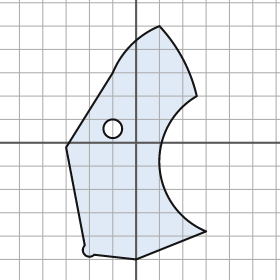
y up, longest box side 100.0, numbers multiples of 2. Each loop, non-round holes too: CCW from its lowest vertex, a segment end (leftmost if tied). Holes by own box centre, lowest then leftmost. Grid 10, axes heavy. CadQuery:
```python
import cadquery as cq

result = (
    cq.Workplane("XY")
    .moveTo(0.0, -50.0)
    .lineTo(30.0, -38.0)
    .threePointArc((10.0, -10.0), (26.0, 20.0))
    .threePointArc((20.0, 36.0), (10.0, 50.0))
    .threePointArc((-2.0, 42.0), (-10.0, 30.0))
    .lineTo(-30.0, -2.0)
    .lineTo(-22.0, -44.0)
    .threePointArc((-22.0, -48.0), (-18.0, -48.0))
    .close()
    .moveTo(-10.0, 6.0)
    .circle(4.0)
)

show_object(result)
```